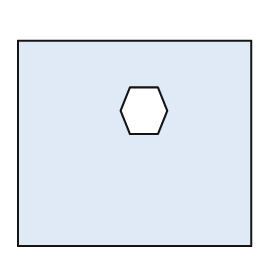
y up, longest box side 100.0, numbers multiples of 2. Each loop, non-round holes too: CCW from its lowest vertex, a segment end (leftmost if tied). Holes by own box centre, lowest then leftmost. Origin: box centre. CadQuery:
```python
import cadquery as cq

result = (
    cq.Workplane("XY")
    .moveTo(-50.0, -44.0)
    .lineTo(50.0, -44.0)
    .lineTo(50.0, 44.0)
    .lineTo(-50.0, 44.0)
    .close()
    .moveTo(-2.0, 4.0)
    .lineTo(10.0, 4.0)
    .lineTo(14.0, 14.0)
    .lineTo(10.0, 24.0)
    .lineTo(-2.0, 24.0)
    .lineTo(-6.0, 14.0)
    .close()
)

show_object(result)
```